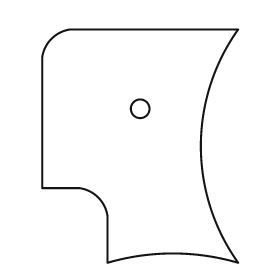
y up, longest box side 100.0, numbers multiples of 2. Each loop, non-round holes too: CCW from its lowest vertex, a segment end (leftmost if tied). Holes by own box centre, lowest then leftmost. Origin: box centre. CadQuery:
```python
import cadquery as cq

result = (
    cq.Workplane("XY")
    .moveTo(-14.0, -50.0)
    .threePointArc((14.0, -46.0), (42.0, -50.0))
    .threePointArc((26.0, 0.0), (42.0, 50.0))
    .lineTo(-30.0, 50.0)
    .threePointArc((-38.0, 46.0), (-42.0, 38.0))
    .lineTo(-42.0, -18.0)
    .lineTo(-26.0, -18.0)
    .threePointArc((-18.0, -22.0), (-14.0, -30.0))
    .close()
    .moveTo(0.0, 16.0)
    .circle(4.0)
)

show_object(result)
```